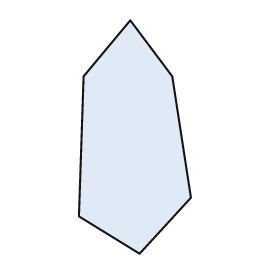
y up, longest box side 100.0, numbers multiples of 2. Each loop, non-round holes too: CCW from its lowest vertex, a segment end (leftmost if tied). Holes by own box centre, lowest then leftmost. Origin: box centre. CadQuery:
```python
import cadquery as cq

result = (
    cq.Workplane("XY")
    .moveTo(2.0, -50.0)
    .lineTo(24.0, -26.0)
    .lineTo(16.0, 26.0)
    .lineTo(-2.0, 50.0)
    .lineTo(-22.0, 26.0)
    .lineTo(-24.0, -34.0)
    .close()
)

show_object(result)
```